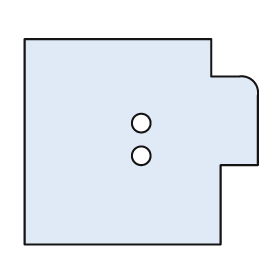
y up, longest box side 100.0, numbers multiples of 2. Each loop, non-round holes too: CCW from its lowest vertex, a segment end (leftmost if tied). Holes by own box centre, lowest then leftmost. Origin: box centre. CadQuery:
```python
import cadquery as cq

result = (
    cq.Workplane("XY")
    .moveTo(-50.0, -44.0)
    .lineTo(34.0, -44.0)
    .lineTo(34.0, -10.0)
    .lineTo(50.0, -10.0)
    .lineTo(50.0, 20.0)
    .threePointArc((48.0, 26.0), (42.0, 28.0))
    .lineTo(30.0, 28.0)
    .lineTo(30.0, 44.0)
    .lineTo(-50.0, 44.0)
    .close()
    .moveTo(0.0, -6.0)
    .circle(4.0)
    .moveTo(0.0, 8.0)
    .circle(4.0)
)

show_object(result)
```